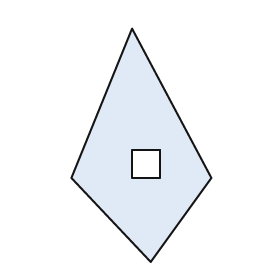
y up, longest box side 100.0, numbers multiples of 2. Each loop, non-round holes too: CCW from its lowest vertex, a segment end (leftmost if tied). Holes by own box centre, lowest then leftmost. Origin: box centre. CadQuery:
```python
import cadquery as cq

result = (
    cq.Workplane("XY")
    .moveTo(4.0, -50.0)
    .lineTo(30.0, -14.0)
    .lineTo(-4.0, 50.0)
    .lineTo(-30.0, -14.0)
    .close()
    .moveTo(-4.0, -14.0)
    .lineTo(8.0, -14.0)
    .lineTo(8.0, -2.0)
    .lineTo(-4.0, -2.0)
    .close()
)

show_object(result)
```